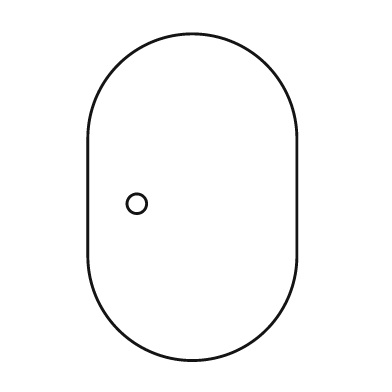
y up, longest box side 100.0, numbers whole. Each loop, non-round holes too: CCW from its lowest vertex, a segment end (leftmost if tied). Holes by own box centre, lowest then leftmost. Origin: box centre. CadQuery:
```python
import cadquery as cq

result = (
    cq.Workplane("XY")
    .moveTo(-32.0, -18.0)
    .threePointArc((0.0, -50.0), (32.0, -18.0))
    .lineTo(32.0, 18.0)
    .threePointArc((0.0, 50.0), (-32.0, 18.0))
    .close()
    .moveTo(-17.0, -2.0)
    .circle(3.0)
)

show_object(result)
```